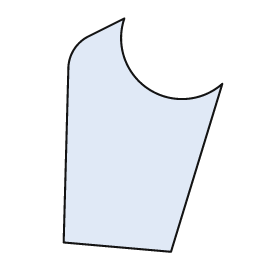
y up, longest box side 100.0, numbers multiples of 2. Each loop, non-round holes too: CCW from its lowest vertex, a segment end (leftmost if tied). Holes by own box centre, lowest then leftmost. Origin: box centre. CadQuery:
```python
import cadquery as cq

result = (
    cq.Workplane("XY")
    .moveTo(12.0, -50.0)
    .lineTo(34.0, 22.0)
    .threePointArc((2.0, 20.0), (-8.0, 50.0))
    .lineTo(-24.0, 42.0)
    .threePointArc((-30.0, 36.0), (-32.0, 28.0))
    .lineTo(-34.0, -46.0)
    .close()
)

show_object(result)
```